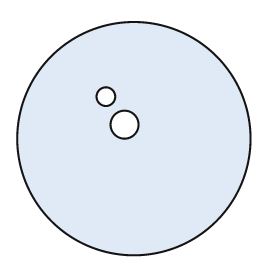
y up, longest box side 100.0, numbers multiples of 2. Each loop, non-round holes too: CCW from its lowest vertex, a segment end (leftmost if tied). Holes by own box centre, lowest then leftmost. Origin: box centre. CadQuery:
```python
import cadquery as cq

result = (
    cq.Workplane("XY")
    .moveTo(0.0, 0.0)
    .circle(50.0)
    .moveTo(-4.0, 6.0)
    .circle(6.0)
    .moveTo(-12.0, 18.0)
    .circle(4.0)
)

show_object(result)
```